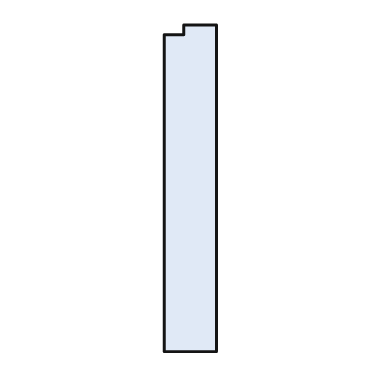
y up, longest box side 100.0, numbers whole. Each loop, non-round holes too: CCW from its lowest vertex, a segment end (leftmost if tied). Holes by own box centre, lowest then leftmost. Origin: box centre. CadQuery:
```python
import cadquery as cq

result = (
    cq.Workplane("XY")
    .moveTo(-8.0, -50.0)
    .lineTo(8.0, -50.0)
    .lineTo(8.0, 50.0)
    .lineTo(-2.0, 50.0)
    .lineTo(-2.0, 47.0)
    .lineTo(-8.0, 47.0)
    .close()
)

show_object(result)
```